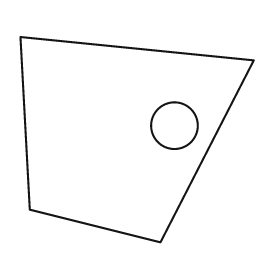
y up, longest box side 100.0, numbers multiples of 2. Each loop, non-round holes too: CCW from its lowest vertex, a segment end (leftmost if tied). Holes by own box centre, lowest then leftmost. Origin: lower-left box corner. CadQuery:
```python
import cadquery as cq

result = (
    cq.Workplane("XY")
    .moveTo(60.0, 0.0)
    .lineTo(100.0, 78.0)
    .lineTo(0.0, 88.0)
    .lineTo(4.0, 14.0)
    .close()
    .moveTo(66.0, 50.0)
    .circle(10.0)
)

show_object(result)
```